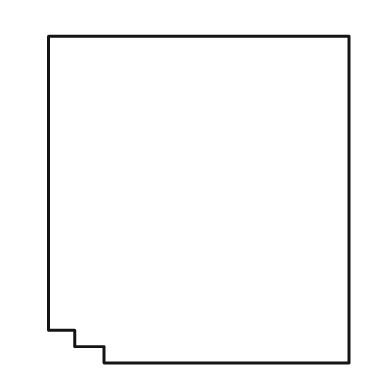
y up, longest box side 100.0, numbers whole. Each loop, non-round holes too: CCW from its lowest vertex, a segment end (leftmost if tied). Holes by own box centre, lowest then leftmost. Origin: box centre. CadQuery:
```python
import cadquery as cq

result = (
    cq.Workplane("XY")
    .moveTo(-29.0, -50.0)
    .lineTo(46.0, -50.0)
    .lineTo(46.0, 50.0)
    .lineTo(-46.0, 50.0)
    .lineTo(-46.0, -40.0)
    .lineTo(-38.0, -40.0)
    .lineTo(-38.0, -45.0)
    .lineTo(-29.0, -45.0)
    .close()
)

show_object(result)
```